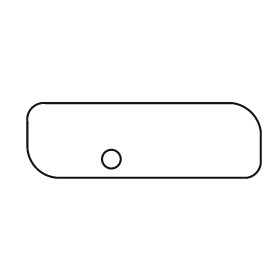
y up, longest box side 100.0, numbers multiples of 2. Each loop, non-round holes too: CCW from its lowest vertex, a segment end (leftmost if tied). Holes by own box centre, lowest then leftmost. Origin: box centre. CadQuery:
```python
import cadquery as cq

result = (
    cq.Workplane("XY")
    .moveTo(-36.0, -16.0)
    .lineTo(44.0, -16.0)
    .threePointArc((48.0, -14.0), (50.0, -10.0))
    .lineTo(50.0, 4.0)
    .threePointArc((46.0, 12.0), (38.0, 16.0))
    .lineTo(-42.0, 16.0)
    .threePointArc((-48.0, 14.0), (-50.0, 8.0))
    .lineTo(-50.0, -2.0)
    .threePointArc((-46.0, -12.0), (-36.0, -16.0))
    .close()
    .moveTo(-14.0, -8.0)
    .circle(4.0)
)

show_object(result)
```